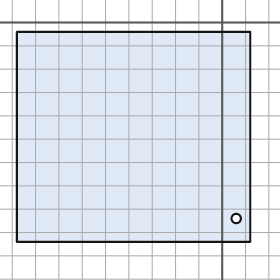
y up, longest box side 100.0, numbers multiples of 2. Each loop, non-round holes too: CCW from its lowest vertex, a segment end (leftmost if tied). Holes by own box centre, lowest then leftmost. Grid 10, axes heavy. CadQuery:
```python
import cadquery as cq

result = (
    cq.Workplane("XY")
    .moveTo(-88.0, -94.0)
    .lineTo(12.0, -94.0)
    .lineTo(12.0, -4.0)
    .lineTo(-88.0, -4.0)
    .close()
    .moveTo(6.0, -84.0)
    .circle(2.0)
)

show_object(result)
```